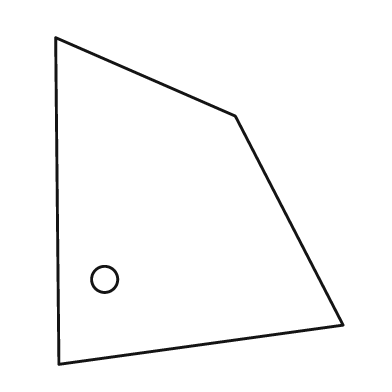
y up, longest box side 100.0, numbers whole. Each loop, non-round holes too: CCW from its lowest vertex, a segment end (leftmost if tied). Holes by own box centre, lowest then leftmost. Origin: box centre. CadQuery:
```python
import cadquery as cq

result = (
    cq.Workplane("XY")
    .moveTo(-43.0, -50.0)
    .lineTo(44.0, -38.0)
    .lineTo(11.0, 26.0)
    .lineTo(-44.0, 50.0)
    .close()
    .moveTo(-29.0, -24.0)
    .circle(4.0)
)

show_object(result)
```